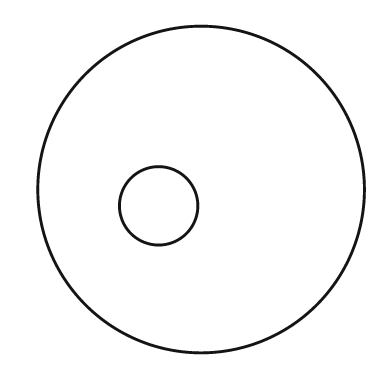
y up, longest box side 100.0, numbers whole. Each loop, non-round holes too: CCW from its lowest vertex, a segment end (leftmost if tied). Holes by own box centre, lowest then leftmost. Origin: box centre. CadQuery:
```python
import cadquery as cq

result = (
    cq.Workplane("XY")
    .moveTo(0.0, 0.0)
    .circle(50.0)
    .moveTo(-13.0, -5.0)
    .circle(12.0)
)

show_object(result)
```